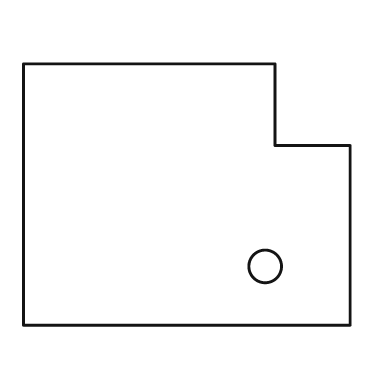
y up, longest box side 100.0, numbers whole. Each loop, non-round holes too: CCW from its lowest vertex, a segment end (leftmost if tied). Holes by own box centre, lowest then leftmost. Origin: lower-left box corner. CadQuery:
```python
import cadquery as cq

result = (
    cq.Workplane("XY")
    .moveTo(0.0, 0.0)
    .lineTo(100.0, 0.0)
    .lineTo(100.0, 55.0)
    .lineTo(77.0, 55.0)
    .lineTo(77.0, 80.0)
    .lineTo(0.0, 80.0)
    .close()
    .moveTo(74.0, 18.0)
    .circle(5.0)
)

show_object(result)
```